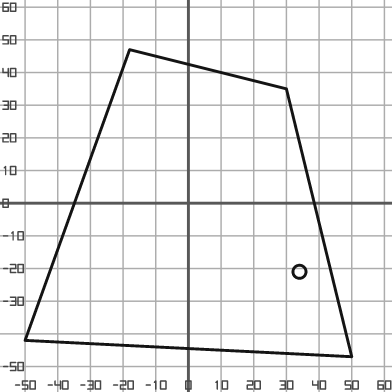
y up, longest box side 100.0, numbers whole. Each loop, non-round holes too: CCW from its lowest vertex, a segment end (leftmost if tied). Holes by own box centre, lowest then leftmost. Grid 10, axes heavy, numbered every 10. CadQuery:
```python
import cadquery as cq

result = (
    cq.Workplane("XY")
    .moveTo(50.0, -47.0)
    .lineTo(30.0, 35.0)
    .lineTo(-18.0, 47.0)
    .lineTo(-50.0, -42.0)
    .close()
    .moveTo(34.0, -21.0)
    .circle(2.0)
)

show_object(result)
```